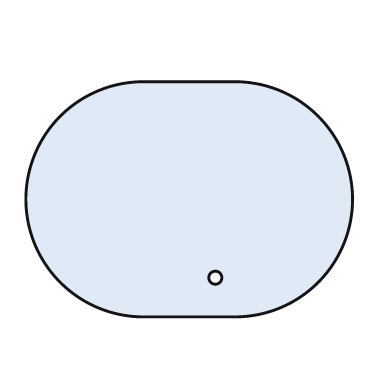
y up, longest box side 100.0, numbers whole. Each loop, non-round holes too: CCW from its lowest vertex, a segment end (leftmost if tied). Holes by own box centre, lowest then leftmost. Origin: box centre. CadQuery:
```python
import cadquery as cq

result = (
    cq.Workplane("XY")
    .moveTo(-14.0, -36.0)
    .lineTo(14.0, -36.0)
    .threePointArc((50.0, 0.0), (14.0, 36.0))
    .lineTo(-14.0, 36.0)
    .threePointArc((-50.0, 0.0), (-14.0, -36.0))
    .close()
    .moveTo(8.0, -24.0)
    .circle(2.0)
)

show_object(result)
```